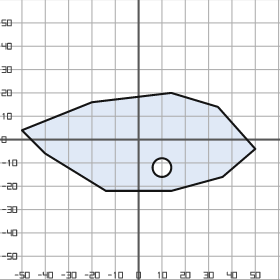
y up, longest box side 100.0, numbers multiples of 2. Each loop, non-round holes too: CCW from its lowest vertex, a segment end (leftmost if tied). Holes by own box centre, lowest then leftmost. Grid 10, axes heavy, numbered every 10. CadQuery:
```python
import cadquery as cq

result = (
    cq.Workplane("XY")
    .moveTo(-14.0, -22.0)
    .lineTo(14.0, -22.0)
    .lineTo(36.0, -16.0)
    .lineTo(50.0, -4.0)
    .lineTo(34.0, 14.0)
    .lineTo(14.0, 20.0)
    .lineTo(-20.0, 16.0)
    .lineTo(-50.0, 4.0)
    .lineTo(-40.0, -6.0)
    .close()
    .moveTo(10.0, -12.0)
    .circle(4.0)
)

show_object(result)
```